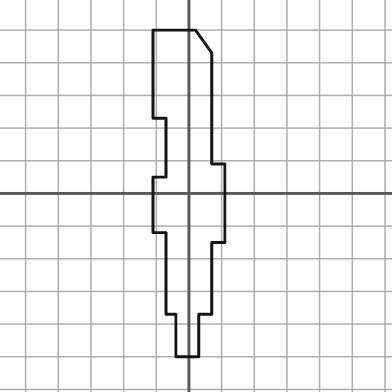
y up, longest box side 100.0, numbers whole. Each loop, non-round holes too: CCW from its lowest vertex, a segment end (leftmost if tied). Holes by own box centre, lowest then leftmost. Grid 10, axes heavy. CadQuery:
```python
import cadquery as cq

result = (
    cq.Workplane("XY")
    .moveTo(-4.0, -50.0)
    .lineTo(3.0, -50.0)
    .lineTo(3.0, -37.0)
    .lineTo(7.0, -37.0)
    .lineTo(7.0, -15.0)
    .lineTo(11.0, -15.0)
    .lineTo(11.0, 9.0)
    .lineTo(7.0, 9.0)
    .lineTo(7.0, 43.0)
    .lineTo(2.0, 50.0)
    .lineTo(-11.0, 50.0)
    .lineTo(-11.0, 23.0)
    .lineTo(-7.0, 23.0)
    .lineTo(-7.0, 5.0)
    .lineTo(-11.0, 5.0)
    .lineTo(-11.0, -12.0)
    .lineTo(-7.0, -12.0)
    .lineTo(-7.0, -37.0)
    .lineTo(-4.0, -37.0)
    .close()
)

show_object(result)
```